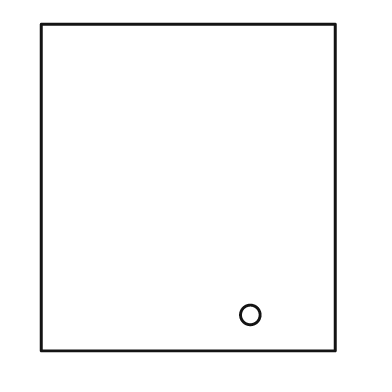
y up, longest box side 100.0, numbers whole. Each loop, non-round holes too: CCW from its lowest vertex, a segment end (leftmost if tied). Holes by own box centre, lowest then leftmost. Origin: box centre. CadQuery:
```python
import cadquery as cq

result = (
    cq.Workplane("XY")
    .moveTo(-45.0, -50.0)
    .lineTo(45.0, -50.0)
    .lineTo(45.0, 50.0)
    .lineTo(-45.0, 50.0)
    .close()
    .moveTo(19.0, -39.0)
    .circle(3.0)
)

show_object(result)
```